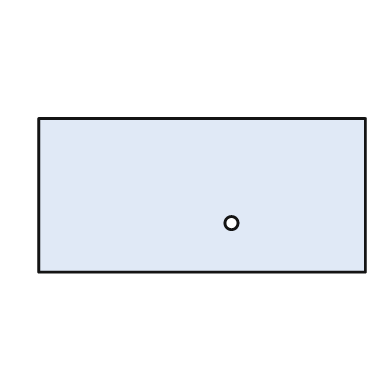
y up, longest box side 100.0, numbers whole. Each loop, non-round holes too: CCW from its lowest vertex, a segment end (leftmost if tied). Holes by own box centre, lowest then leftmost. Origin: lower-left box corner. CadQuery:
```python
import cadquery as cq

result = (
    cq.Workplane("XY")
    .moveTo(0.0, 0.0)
    .lineTo(100.0, 0.0)
    .lineTo(100.0, 47.0)
    .lineTo(0.0, 47.0)
    .close()
    .moveTo(59.0, 15.0)
    .circle(2.0)
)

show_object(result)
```